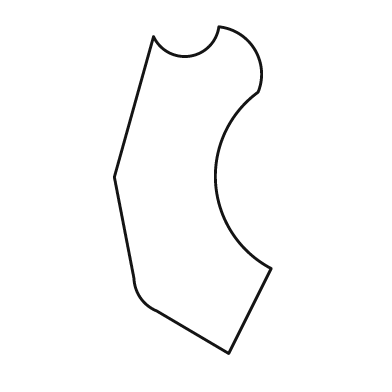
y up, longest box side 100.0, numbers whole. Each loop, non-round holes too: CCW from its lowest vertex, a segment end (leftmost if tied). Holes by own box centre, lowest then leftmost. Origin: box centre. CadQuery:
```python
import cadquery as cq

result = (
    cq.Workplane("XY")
    .moveTo(11.0, -50.0)
    .lineTo(24.0, -24.0)
    .threePointArc((7.0, 2.0), (20.0, 30.0))
    .threePointArc((19.0, 43.0), (8.0, 50.0))
    .threePointArc((-1.0, 41.0), (-12.0, 47.0))
    .lineTo(-24.0, 4.0)
    .lineTo(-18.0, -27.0)
    .threePointArc((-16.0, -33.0), (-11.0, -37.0))
    .close()
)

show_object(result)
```